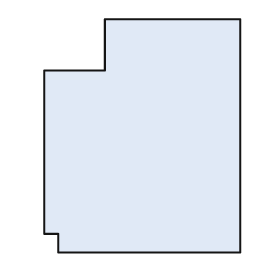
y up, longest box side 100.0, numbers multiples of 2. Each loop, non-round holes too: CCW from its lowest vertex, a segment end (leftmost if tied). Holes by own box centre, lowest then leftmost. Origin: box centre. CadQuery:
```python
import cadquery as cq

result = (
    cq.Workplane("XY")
    .moveTo(-36.0, -50.0)
    .lineTo(42.0, -50.0)
    .lineTo(42.0, 50.0)
    .lineTo(-16.0, 50.0)
    .lineTo(-16.0, 28.0)
    .lineTo(-42.0, 28.0)
    .lineTo(-42.0, -42.0)
    .lineTo(-36.0, -42.0)
    .close()
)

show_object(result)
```